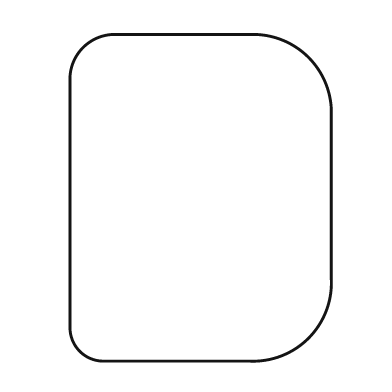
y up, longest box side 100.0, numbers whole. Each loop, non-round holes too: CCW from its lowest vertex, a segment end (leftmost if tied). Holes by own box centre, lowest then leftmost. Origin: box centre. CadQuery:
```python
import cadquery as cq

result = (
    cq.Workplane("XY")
    .moveTo(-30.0, -50.0)
    .lineTo(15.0, -50.0)
    .threePointArc((33.0, -43.0), (40.0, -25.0))
    .lineTo(40.0, 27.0)
    .threePointArc((33.0, 43.0), (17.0, 50.0))
    .lineTo(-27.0, 50.0)
    .threePointArc((-36.0, 46.0), (-40.0, 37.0))
    .lineTo(-40.0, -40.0)
    .threePointArc((-37.0, -47.0), (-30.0, -50.0))
    .close()
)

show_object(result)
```